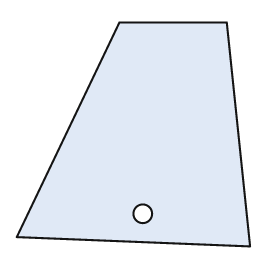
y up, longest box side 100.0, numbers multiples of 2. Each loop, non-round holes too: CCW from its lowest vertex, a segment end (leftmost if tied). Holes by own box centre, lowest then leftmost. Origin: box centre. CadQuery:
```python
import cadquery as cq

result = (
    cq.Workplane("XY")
    .moveTo(50.0, -48.0)
    .lineTo(40.0, 48.0)
    .lineTo(-6.0, 48.0)
    .lineTo(-50.0, -44.0)
    .close()
    .moveTo(4.0, -34.0)
    .circle(4.0)
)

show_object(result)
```